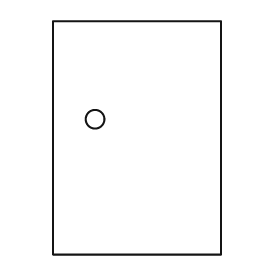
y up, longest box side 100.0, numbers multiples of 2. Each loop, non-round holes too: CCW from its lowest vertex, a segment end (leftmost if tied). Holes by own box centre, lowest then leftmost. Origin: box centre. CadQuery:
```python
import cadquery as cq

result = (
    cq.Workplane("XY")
    .moveTo(-36.0, -50.0)
    .lineTo(36.0, -50.0)
    .lineTo(36.0, 50.0)
    .lineTo(-36.0, 50.0)
    .close()
    .moveTo(-18.0, 8.0)
    .circle(4.0)
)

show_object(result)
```